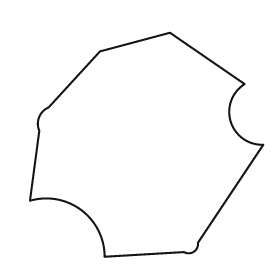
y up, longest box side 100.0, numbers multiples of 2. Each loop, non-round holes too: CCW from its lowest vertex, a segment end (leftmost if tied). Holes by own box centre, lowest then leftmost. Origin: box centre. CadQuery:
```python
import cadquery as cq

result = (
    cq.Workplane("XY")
    .moveTo(-18.0, -48.0)
    .lineTo(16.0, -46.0)
    .threePointArc((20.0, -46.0), (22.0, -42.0))
    .lineTo(50.0, 0.0)
    .threePointArc((36.0, 10.0), (42.0, 26.0))
    .lineTo(10.0, 48.0)
    .lineTo(-20.0, 40.0)
    .lineTo(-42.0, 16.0)
    .threePointArc((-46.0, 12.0), (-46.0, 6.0))
    .lineTo(-50.0, -24.0)
    .threePointArc((-28.0, -28.0), (-18.0, -48.0))
    .close()
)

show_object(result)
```